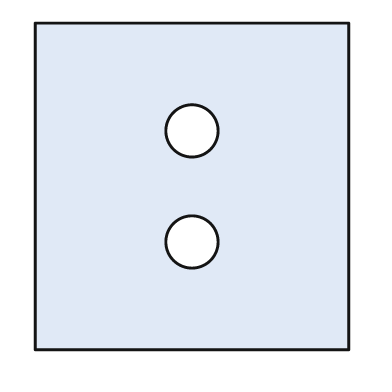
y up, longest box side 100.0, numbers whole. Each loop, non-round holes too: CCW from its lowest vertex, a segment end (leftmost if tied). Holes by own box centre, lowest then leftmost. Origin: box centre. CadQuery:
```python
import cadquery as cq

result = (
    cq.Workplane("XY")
    .moveTo(-48.0, -50.0)
    .lineTo(48.0, -50.0)
    .lineTo(48.0, 50.0)
    .lineTo(-48.0, 50.0)
    .close()
    .moveTo(0.0, -17.0)
    .circle(8.0)
    .moveTo(0.0, 17.0)
    .circle(8.0)
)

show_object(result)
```